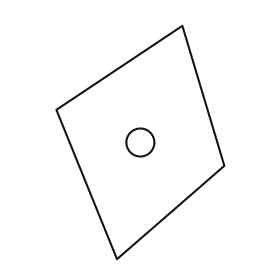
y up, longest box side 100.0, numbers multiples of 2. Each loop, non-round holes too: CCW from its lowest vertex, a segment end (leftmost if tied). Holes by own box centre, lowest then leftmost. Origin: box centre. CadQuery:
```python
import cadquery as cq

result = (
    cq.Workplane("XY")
    .moveTo(-10.0, -50.0)
    .lineTo(36.0, -10.0)
    .lineTo(18.0, 50.0)
    .lineTo(-36.0, 14.0)
    .close()
    .moveTo(0.0, 0.0)
    .circle(6.0)
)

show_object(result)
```